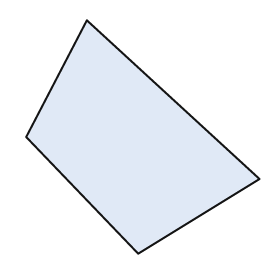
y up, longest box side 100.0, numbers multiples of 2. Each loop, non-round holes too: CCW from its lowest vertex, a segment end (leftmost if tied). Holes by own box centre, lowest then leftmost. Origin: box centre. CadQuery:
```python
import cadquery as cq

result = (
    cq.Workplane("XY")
    .moveTo(-2.0, -50.0)
    .lineTo(50.0, -18.0)
    .lineTo(-24.0, 50.0)
    .lineTo(-50.0, 0.0)
    .close()
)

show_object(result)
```